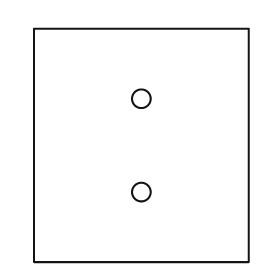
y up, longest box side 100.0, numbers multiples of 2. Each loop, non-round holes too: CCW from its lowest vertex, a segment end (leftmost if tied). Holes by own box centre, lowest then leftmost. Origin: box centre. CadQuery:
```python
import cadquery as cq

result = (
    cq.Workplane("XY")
    .moveTo(-46.0, -50.0)
    .lineTo(46.0, -50.0)
    .lineTo(46.0, 50.0)
    .lineTo(-46.0, 50.0)
    .close()
    .moveTo(0.0, -20.0)
    .circle(4.0)
    .moveTo(0.0, 20.0)
    .circle(4.0)
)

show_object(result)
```